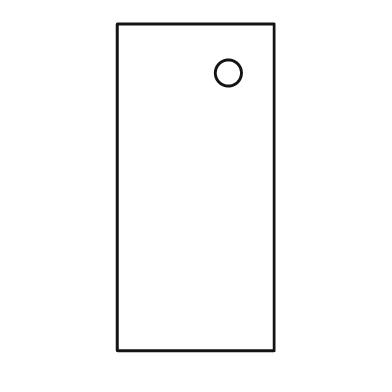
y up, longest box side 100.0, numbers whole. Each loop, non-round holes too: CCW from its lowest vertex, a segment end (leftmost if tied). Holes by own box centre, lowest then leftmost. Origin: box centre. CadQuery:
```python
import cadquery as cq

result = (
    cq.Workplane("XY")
    .moveTo(-24.0, -50.0)
    .lineTo(24.0, -50.0)
    .lineTo(24.0, 50.0)
    .lineTo(-24.0, 50.0)
    .close()
    .moveTo(10.0, 35.0)
    .circle(4.0)
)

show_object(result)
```